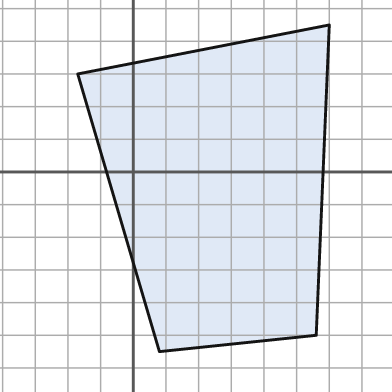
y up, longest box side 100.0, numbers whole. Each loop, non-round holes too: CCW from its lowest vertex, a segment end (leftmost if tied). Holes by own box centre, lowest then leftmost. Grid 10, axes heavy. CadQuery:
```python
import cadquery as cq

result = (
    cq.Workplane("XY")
    .moveTo(8.0, -55.0)
    .lineTo(56.0, -50.0)
    .lineTo(60.0, 45.0)
    .lineTo(-17.0, 30.0)
    .close()
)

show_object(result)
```